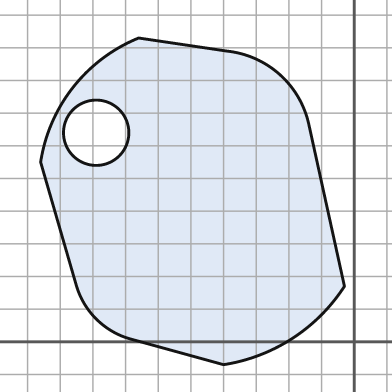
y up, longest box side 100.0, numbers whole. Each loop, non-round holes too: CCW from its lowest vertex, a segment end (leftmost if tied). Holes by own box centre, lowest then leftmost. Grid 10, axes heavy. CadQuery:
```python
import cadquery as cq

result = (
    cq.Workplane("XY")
    .moveTo(-40.0, -7.0)
    .threePointArc((-19.0, 1.0), (-3.0, 17.0))
    .lineTo(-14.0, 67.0)
    .threePointArc((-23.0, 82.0), (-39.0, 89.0))
    .lineTo(-66.0, 93.0)
    .threePointArc((-86.0, 78.0), (-96.0, 55.0))
    .lineTo(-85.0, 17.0)
    .threePointArc((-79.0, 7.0), (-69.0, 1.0))
    .close()
    .moveTo(-79.0, 64.0)
    .circle(10.0)
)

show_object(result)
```